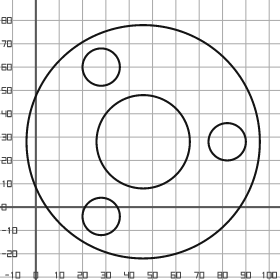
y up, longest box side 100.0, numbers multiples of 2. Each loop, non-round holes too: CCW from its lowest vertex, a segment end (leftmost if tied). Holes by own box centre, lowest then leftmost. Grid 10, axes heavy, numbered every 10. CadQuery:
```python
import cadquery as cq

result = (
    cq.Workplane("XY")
    .moveTo(46.0, 28.0)
    .circle(50.0)
    .moveTo(28.0, -4.0)
    .circle(8.0)
    .moveTo(46.0, 28.0)
    .circle(20.0)
    .moveTo(82.0, 28.0)
    .circle(8.0)
    .moveTo(28.0, 60.0)
    .circle(8.0)
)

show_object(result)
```